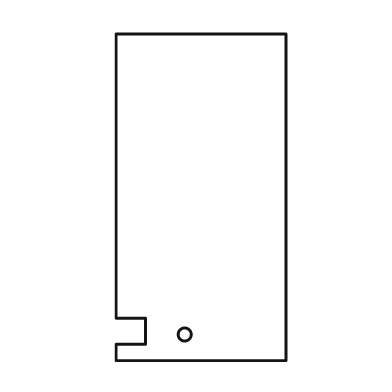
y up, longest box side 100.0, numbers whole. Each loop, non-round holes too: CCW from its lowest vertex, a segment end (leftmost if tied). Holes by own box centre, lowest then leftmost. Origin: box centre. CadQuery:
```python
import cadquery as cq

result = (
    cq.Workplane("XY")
    .moveTo(-26.0, -50.0)
    .lineTo(26.0, -50.0)
    .lineTo(26.0, 50.0)
    .lineTo(-26.0, 50.0)
    .lineTo(-26.0, -37.0)
    .lineTo(-17.0, -37.0)
    .lineTo(-17.0, -45.0)
    .lineTo(-26.0, -45.0)
    .close()
    .moveTo(-5.0, -42.0)
    .circle(2.0)
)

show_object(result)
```